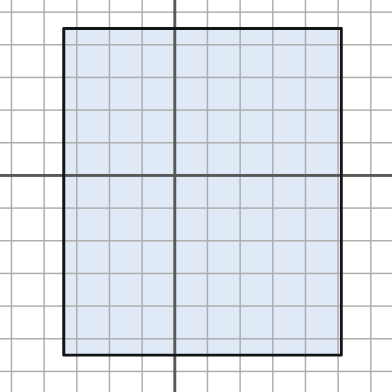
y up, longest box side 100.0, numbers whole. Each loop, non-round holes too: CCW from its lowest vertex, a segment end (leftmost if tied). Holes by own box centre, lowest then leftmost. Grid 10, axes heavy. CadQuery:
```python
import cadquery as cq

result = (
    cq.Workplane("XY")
    .moveTo(-34.0, -55.0)
    .lineTo(51.0, -55.0)
    .lineTo(51.0, 45.0)
    .lineTo(-34.0, 45.0)
    .close()
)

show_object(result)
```